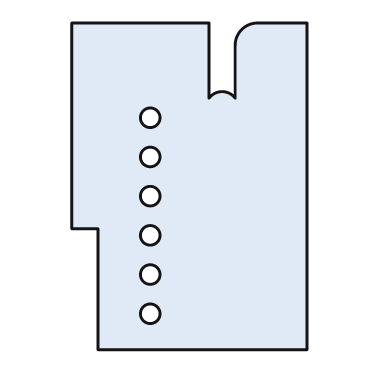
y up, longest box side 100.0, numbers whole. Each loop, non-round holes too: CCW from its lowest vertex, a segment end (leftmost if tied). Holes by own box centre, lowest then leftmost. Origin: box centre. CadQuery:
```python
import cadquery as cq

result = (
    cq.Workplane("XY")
    .moveTo(-28.0, -50.0)
    .lineTo(36.0, -50.0)
    .lineTo(36.0, 50.0)
    .lineTo(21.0, 50.0)
    .threePointArc((16.0, 48.0), (14.0, 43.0))
    .lineTo(14.0, 27.0)
    .threePointArc((10.0, 29.0), (6.0, 27.0))
    .lineTo(6.0, 50.0)
    .lineTo(-36.0, 50.0)
    .lineTo(-36.0, -13.0)
    .lineTo(-28.0, -13.0)
    .close()
    .moveTo(-12.0, -39.0)
    .circle(3.0)
    .moveTo(-12.0, -27.0)
    .circle(3.0)
    .moveTo(-12.0, -15.0)
    .circle(3.0)
    .moveTo(-12.0, -3.0)
    .circle(3.0)
    .moveTo(-12.0, 9.0)
    .circle(3.0)
    .moveTo(-12.0, 21.0)
    .circle(3.0)
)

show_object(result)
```